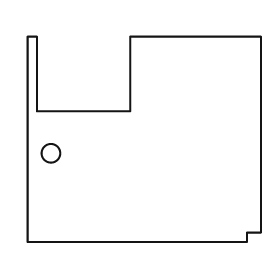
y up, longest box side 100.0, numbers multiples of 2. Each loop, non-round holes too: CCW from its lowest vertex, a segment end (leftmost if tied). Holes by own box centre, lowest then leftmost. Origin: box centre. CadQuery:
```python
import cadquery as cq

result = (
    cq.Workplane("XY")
    .moveTo(-50.0, -44.0)
    .lineTo(44.0, -44.0)
    .lineTo(44.0, -40.0)
    .lineTo(50.0, -40.0)
    .lineTo(50.0, 44.0)
    .lineTo(-6.0, 44.0)
    .lineTo(-6.0, 12.0)
    .lineTo(-46.0, 12.0)
    .lineTo(-46.0, 44.0)
    .lineTo(-50.0, 44.0)
    .close()
    .moveTo(-40.0, -6.0)
    .circle(4.0)
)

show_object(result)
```